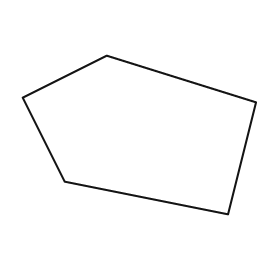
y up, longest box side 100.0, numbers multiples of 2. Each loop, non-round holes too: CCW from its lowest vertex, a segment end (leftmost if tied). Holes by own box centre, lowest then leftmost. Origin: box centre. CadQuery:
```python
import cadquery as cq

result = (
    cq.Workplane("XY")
    .moveTo(38.0, -34.0)
    .lineTo(50.0, 14.0)
    .lineTo(-14.0, 34.0)
    .lineTo(-50.0, 16.0)
    .lineTo(-32.0, -20.0)
    .close()
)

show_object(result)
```